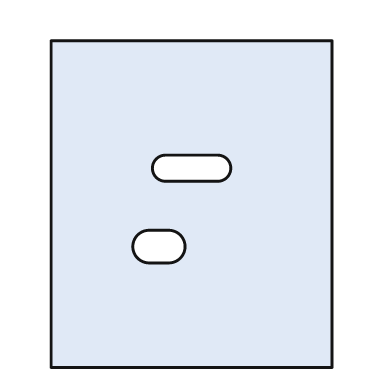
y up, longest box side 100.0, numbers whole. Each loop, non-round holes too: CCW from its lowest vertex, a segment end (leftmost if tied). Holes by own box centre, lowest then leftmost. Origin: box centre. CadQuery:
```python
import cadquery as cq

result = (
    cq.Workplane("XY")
    .moveTo(-43.0, -50.0)
    .lineTo(43.0, -50.0)
    .lineTo(43.0, 50.0)
    .lineTo(-43.0, 50.0)
    .close()
    .moveTo(-13.0, -18.0)
    .lineTo(-7.0, -18.0)
    .threePointArc((-2.0, -13.0), (-7.0, -8.0))
    .lineTo(-13.0, -8.0)
    .threePointArc((-18.0, -13.0), (-13.0, -18.0))
    .close()
    .moveTo(-8.0, 7.0)
    .lineTo(8.0, 7.0)
    .threePointArc((12.0, 11.0), (8.0, 15.0))
    .lineTo(-8.0, 15.0)
    .threePointArc((-12.0, 11.0), (-8.0, 7.0))
    .close()
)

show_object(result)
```